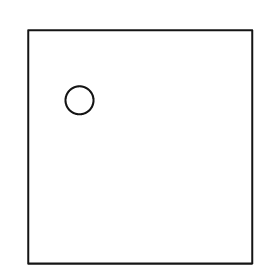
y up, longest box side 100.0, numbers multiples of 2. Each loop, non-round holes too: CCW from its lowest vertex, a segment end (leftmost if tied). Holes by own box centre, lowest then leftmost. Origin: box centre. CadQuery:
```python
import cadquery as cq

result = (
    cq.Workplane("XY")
    .moveTo(-48.0, -50.0)
    .lineTo(48.0, -50.0)
    .lineTo(48.0, 50.0)
    .lineTo(-48.0, 50.0)
    .close()
    .moveTo(-26.0, 20.0)
    .circle(6.0)
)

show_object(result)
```